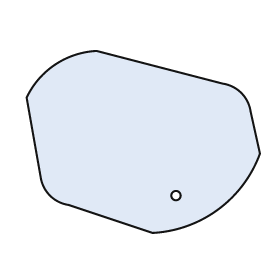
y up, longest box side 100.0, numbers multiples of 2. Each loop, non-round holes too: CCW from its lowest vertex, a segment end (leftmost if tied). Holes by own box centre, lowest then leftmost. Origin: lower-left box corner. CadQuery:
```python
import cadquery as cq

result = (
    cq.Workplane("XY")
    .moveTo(54.0, 0.0)
    .threePointArc((82.0, 10.0), (100.0, 34.0))
    .lineTo(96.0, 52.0)
    .threePointArc((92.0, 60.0), (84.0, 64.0))
    .lineTo(30.0, 78.0)
    .threePointArc((12.0, 72.0), (0.0, 58.0))
    .lineTo(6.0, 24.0)
    .threePointArc((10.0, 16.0), (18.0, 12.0))
    .close()
    .moveTo(64.0, 16.0)
    .circle(2.0)
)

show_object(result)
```